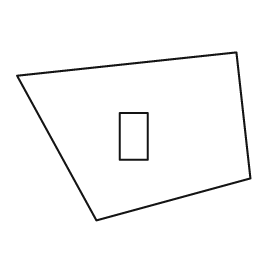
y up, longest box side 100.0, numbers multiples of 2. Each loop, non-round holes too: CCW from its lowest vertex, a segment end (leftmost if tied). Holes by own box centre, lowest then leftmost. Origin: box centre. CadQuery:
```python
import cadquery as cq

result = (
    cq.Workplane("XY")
    .moveTo(-16.0, -36.0)
    .lineTo(50.0, -18.0)
    .lineTo(44.0, 36.0)
    .lineTo(-50.0, 26.0)
    .close()
    .moveTo(-6.0, -10.0)
    .lineTo(6.0, -10.0)
    .lineTo(6.0, 10.0)
    .lineTo(-6.0, 10.0)
    .close()
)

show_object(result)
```